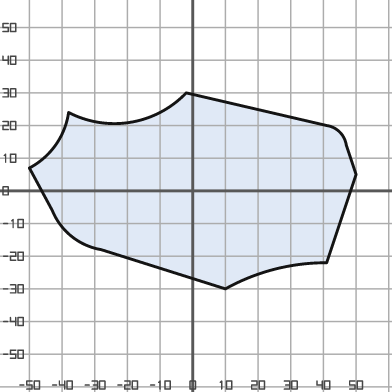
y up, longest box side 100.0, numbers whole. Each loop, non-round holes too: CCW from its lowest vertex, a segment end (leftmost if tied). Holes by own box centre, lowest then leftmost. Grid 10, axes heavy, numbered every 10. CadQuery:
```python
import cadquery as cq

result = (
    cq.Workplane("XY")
    .moveTo(10.0, -30.0)
    .threePointArc((25.0, -24.0), (41.0, -22.0))
    .lineTo(50.0, 5.0)
    .lineTo(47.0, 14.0)
    .threePointArc((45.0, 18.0), (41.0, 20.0))
    .lineTo(-2.0, 30.0)
    .threePointArc((-19.0, 21.0), (-38.0, 24.0))
    .threePointArc((-42.0, 14.0), (-50.0, 7.0))
    .lineTo(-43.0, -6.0)
    .threePointArc((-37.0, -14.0), (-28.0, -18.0))
    .close()
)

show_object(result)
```